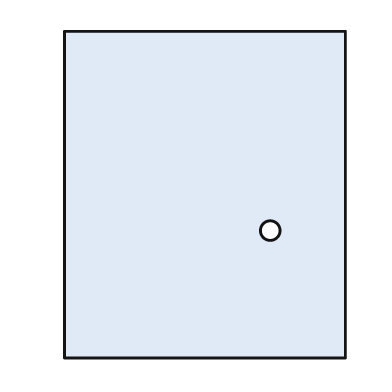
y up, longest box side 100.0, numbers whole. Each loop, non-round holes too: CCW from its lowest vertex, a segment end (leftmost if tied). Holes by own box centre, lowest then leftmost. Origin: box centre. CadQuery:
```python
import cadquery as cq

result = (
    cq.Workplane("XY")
    .moveTo(-43.0, -50.0)
    .lineTo(43.0, -50.0)
    .lineTo(43.0, 50.0)
    .lineTo(-43.0, 50.0)
    .close()
    .moveTo(20.0, -11.0)
    .circle(3.0)
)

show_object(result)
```